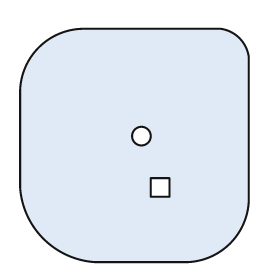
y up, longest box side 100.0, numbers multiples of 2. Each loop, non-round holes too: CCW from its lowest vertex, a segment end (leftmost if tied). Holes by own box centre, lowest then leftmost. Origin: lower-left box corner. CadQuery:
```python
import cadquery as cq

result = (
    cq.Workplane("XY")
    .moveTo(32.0, 0.0)
    .lineTo(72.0, 0.0)
    .threePointArc((90.0, 8.0), (98.0, 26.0))
    .lineTo(98.0, 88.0)
    .threePointArc((94.0, 96.0), (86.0, 100.0))
    .lineTo(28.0, 100.0)
    .threePointArc((8.0, 92.0), (0.0, 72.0))
    .lineTo(0.0, 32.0)
    .threePointArc((10.0, 10.0), (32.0, 0.0))
    .close()
    .moveTo(56.0, 28.0)
    .lineTo(64.0, 28.0)
    .lineTo(64.0, 36.0)
    .lineTo(56.0, 36.0)
    .close()
    .moveTo(52.0, 54.0)
    .circle(4.0)
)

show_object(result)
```